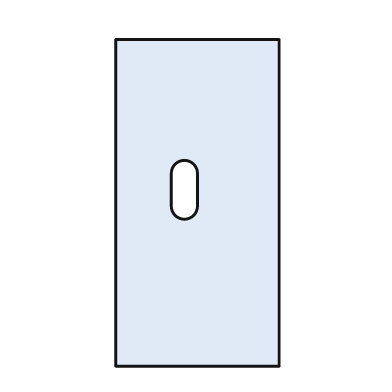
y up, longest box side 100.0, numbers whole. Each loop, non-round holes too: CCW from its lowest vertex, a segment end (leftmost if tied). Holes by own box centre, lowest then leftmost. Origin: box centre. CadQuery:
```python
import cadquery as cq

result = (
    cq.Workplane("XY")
    .moveTo(-25.0, -50.0)
    .lineTo(25.0, -50.0)
    .lineTo(25.0, 50.0)
    .lineTo(-25.0, 50.0)
    .close()
    .moveTo(-8.0, -1.0)
    .threePointArc((-4.0, -5.0), (0.0, -1.0))
    .lineTo(0.0, 9.0)
    .threePointArc((-4.0, 13.0), (-8.0, 9.0))
    .close()
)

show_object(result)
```